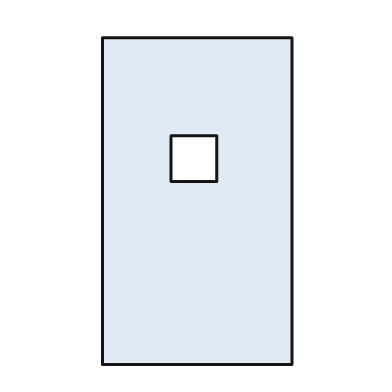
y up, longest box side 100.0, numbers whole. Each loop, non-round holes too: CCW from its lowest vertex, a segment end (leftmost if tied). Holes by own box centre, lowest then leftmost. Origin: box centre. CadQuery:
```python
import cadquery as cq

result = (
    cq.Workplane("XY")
    .moveTo(-29.0, -50.0)
    .lineTo(29.0, -50.0)
    .lineTo(29.0, 50.0)
    .lineTo(-29.0, 50.0)
    .close()
    .moveTo(-8.0, 6.0)
    .lineTo(6.0, 6.0)
    .lineTo(6.0, 20.0)
    .lineTo(-8.0, 20.0)
    .close()
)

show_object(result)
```